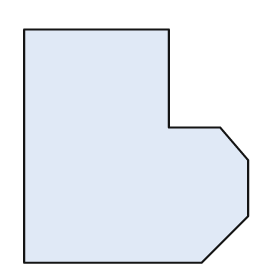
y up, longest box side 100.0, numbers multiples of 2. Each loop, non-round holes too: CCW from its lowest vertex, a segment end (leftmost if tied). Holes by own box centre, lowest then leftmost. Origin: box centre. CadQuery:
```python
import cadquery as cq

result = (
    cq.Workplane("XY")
    .moveTo(-48.0, -50.0)
    .lineTo(28.0, -50.0)
    .lineTo(48.0, -30.0)
    .lineTo(48.0, -6.0)
    .lineTo(36.0, 8.0)
    .lineTo(14.0, 8.0)
    .lineTo(14.0, 50.0)
    .lineTo(-48.0, 50.0)
    .close()
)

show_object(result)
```